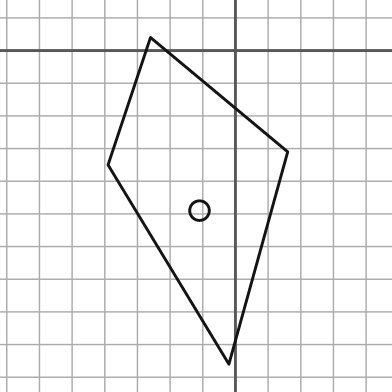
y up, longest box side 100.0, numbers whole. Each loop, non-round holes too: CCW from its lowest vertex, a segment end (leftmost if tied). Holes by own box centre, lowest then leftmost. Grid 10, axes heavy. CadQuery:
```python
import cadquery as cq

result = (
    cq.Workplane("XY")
    .moveTo(-2.0, -96.0)
    .lineTo(16.0, -31.0)
    .lineTo(-26.0, 4.0)
    .lineTo(-39.0, -35.0)
    .close()
    .moveTo(-11.0, -49.0)
    .circle(3.0)
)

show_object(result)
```